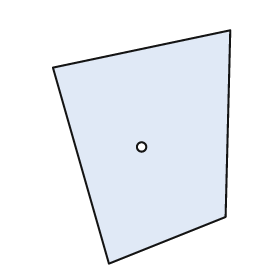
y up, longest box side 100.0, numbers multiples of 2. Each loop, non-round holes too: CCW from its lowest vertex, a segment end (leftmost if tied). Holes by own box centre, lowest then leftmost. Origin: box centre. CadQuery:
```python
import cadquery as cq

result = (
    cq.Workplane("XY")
    .moveTo(-14.0, -50.0)
    .lineTo(36.0, -30.0)
    .lineTo(38.0, 50.0)
    .lineTo(-38.0, 34.0)
    .close()
    .moveTo(0.0, 0.0)
    .circle(2.0)
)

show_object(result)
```